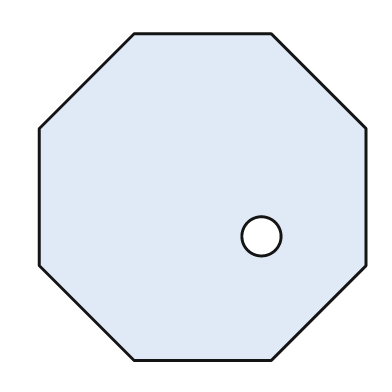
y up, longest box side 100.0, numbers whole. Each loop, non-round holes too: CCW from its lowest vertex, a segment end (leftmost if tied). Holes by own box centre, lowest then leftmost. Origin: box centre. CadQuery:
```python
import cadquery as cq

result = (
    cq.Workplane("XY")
    .moveTo(-21.0, -50.0)
    .lineTo(21.0, -50.0)
    .lineTo(50.0, -21.0)
    .lineTo(50.0, 21.0)
    .lineTo(21.0, 50.0)
    .lineTo(-21.0, 50.0)
    .lineTo(-50.0, 21.0)
    .lineTo(-50.0, -21.0)
    .close()
    .moveTo(18.0, -12.0)
    .circle(6.0)
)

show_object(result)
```